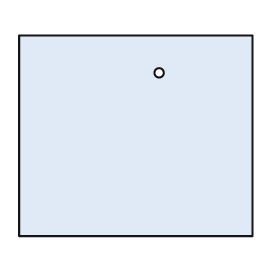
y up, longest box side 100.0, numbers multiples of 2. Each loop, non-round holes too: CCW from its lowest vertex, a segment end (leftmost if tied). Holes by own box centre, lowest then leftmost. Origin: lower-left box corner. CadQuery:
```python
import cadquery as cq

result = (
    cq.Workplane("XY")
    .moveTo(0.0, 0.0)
    .lineTo(100.0, 0.0)
    .lineTo(100.0, 86.0)
    .lineTo(0.0, 86.0)
    .close()
    .moveTo(60.0, 70.0)
    .circle(2.0)
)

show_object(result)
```